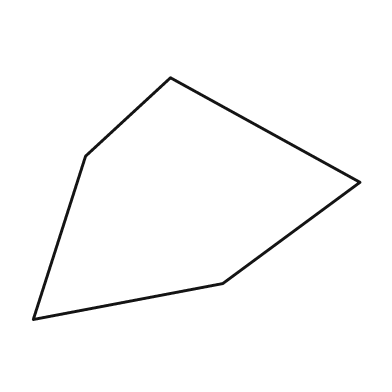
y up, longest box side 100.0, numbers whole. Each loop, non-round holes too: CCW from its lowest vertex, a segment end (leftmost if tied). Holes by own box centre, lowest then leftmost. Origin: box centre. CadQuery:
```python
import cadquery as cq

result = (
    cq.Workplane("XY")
    .moveTo(-50.0, -37.0)
    .lineTo(8.0, -26.0)
    .lineTo(50.0, 5.0)
    .lineTo(-8.0, 37.0)
    .lineTo(-34.0, 13.0)
    .close()
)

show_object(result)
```